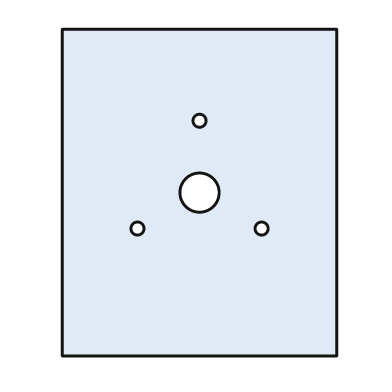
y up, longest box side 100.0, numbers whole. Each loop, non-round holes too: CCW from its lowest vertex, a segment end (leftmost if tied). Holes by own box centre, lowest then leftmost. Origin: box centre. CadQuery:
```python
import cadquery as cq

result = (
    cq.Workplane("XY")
    .moveTo(-42.0, -50.0)
    .lineTo(42.0, -50.0)
    .lineTo(42.0, 50.0)
    .lineTo(-42.0, 50.0)
    .close()
    .moveTo(-19.0, -11.0)
    .circle(2.0)
    .moveTo(19.0, -11.0)
    .circle(2.0)
    .moveTo(0.0, 0.0)
    .circle(6.0)
    .moveTo(0.0, 22.0)
    .circle(2.0)
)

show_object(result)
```